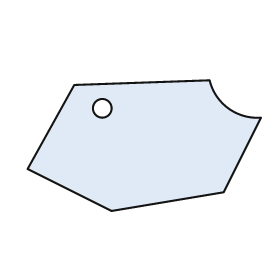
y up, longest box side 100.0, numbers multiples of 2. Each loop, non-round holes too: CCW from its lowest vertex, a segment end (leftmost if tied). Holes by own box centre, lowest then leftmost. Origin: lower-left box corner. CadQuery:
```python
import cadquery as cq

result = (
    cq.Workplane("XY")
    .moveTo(36.0, 0.0)
    .lineTo(84.0, 8.0)
    .lineTo(100.0, 40.0)
    .threePointArc((86.0, 44.0), (78.0, 56.0))
    .lineTo(20.0, 54.0)
    .lineTo(0.0, 18.0)
    .close()
    .moveTo(32.0, 44.0)
    .circle(4.0)
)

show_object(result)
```